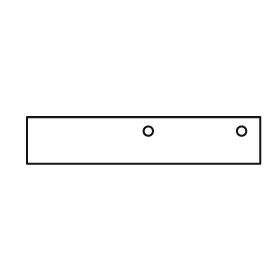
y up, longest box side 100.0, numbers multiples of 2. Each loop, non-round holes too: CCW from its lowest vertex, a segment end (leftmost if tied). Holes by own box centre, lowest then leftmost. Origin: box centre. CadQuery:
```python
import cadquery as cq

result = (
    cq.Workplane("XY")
    .moveTo(-50.0, -10.0)
    .lineTo(50.0, -10.0)
    .lineTo(50.0, 10.0)
    .lineTo(-50.0, 10.0)
    .close()
    .moveTo(2.0, 4.0)
    .circle(2.0)
    .moveTo(42.0, 4.0)
    .circle(2.0)
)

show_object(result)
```